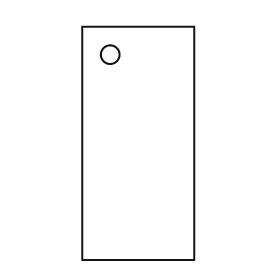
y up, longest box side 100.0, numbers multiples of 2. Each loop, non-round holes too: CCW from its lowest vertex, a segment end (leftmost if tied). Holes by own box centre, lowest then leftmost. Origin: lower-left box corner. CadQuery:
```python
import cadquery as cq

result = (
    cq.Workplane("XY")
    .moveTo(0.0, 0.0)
    .lineTo(48.0, 0.0)
    .lineTo(48.0, 100.0)
    .lineTo(0.0, 100.0)
    .close()
    .moveTo(12.0, 88.0)
    .circle(4.0)
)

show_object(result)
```